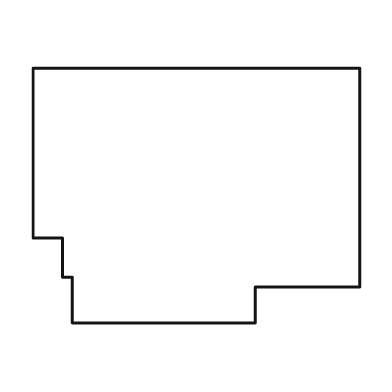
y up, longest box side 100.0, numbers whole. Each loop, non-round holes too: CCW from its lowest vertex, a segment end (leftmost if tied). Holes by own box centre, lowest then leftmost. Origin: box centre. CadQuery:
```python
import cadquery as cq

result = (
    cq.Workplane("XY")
    .moveTo(-38.0, -39.0)
    .lineTo(18.0, -39.0)
    .lineTo(18.0, -28.0)
    .lineTo(50.0, -28.0)
    .lineTo(50.0, 39.0)
    .lineTo(-50.0, 39.0)
    .lineTo(-50.0, -13.0)
    .lineTo(-41.0, -13.0)
    .lineTo(-41.0, -25.0)
    .lineTo(-38.0, -25.0)
    .close()
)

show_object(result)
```